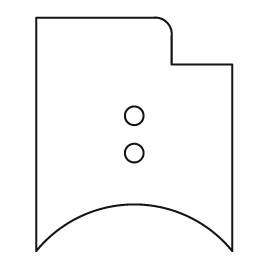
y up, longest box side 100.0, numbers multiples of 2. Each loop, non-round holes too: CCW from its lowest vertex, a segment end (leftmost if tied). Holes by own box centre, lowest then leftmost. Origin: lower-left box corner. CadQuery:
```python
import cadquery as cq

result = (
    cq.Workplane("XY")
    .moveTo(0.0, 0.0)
    .threePointArc((42.0, 20.0), (84.0, 0.0))
    .lineTo(84.0, 80.0)
    .lineTo(58.0, 80.0)
    .lineTo(58.0, 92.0)
    .threePointArc((56.0, 98.0), (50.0, 100.0))
    .lineTo(0.0, 100.0)
    .close()
    .moveTo(42.0, 42.0)
    .circle(4.0)
    .moveTo(42.0, 58.0)
    .circle(4.0)
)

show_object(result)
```